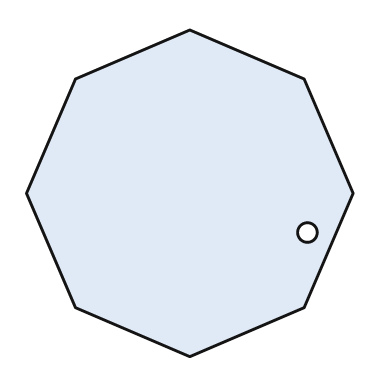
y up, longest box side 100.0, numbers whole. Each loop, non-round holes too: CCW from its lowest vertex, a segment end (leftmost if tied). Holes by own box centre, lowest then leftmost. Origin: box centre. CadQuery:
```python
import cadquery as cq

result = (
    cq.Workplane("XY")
    .moveTo(0.0, -50.0)
    .lineTo(35.0, -35.0)
    .lineTo(50.0, 0.0)
    .lineTo(35.0, 35.0)
    .lineTo(0.0, 50.0)
    .lineTo(-35.0, 35.0)
    .lineTo(-50.0, 0.0)
    .lineTo(-35.0, -35.0)
    .close()
    .moveTo(36.0, -12.0)
    .circle(3.0)
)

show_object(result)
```